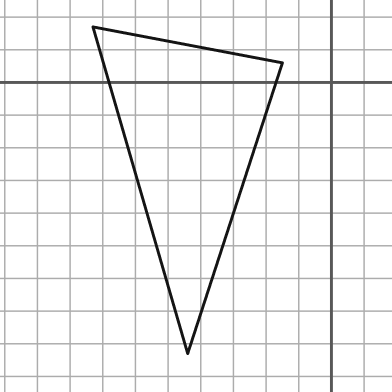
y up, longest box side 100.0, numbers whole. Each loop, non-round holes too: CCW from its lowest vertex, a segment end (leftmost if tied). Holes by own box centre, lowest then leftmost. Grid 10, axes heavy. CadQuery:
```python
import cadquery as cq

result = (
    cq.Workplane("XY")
    .moveTo(-44.0, -83.0)
    .lineTo(-15.0, 6.0)
    .lineTo(-73.0, 17.0)
    .close()
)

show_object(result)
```